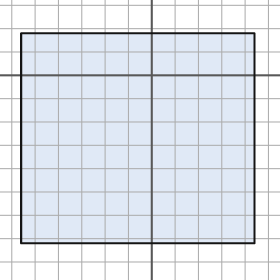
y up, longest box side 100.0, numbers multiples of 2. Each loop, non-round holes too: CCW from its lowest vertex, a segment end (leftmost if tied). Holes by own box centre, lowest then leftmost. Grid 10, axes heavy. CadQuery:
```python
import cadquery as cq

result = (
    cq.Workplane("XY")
    .moveTo(-56.0, -72.0)
    .lineTo(44.0, -72.0)
    .lineTo(44.0, 18.0)
    .lineTo(-56.0, 18.0)
    .close()
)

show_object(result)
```